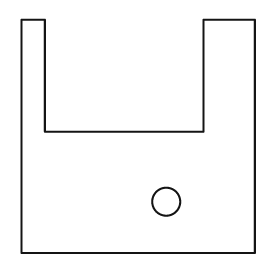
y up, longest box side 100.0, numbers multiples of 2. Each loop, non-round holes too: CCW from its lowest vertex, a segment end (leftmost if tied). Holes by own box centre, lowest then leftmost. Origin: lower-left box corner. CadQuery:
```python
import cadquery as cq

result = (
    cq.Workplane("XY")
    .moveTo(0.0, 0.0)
    .lineTo(100.0, 0.0)
    .lineTo(100.0, 100.0)
    .lineTo(78.0, 100.0)
    .lineTo(78.0, 52.0)
    .lineTo(10.0, 52.0)
    .lineTo(10.0, 100.0)
    .lineTo(0.0, 100.0)
    .close()
    .moveTo(62.0, 22.0)
    .circle(6.0)
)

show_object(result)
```